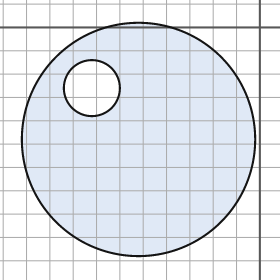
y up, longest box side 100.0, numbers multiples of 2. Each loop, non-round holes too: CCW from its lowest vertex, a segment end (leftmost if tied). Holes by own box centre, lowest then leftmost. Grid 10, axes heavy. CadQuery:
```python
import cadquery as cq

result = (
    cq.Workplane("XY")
    .moveTo(-52.0, -48.0)
    .circle(50.0)
    .moveTo(-72.0, -26.0)
    .circle(12.0)
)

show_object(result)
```